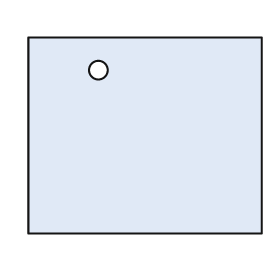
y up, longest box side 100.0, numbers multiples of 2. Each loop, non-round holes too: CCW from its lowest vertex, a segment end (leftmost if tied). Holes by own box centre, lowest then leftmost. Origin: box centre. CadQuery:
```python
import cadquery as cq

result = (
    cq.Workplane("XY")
    .moveTo(-50.0, -42.0)
    .lineTo(50.0, -42.0)
    .lineTo(50.0, 42.0)
    .lineTo(-50.0, 42.0)
    .close()
    .moveTo(-20.0, 28.0)
    .circle(4.0)
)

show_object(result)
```